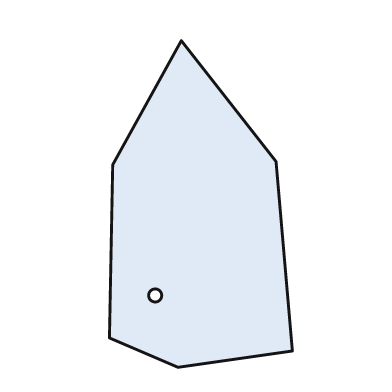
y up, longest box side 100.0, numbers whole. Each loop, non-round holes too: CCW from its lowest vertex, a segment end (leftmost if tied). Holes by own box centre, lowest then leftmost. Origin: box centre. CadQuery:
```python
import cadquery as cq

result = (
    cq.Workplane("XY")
    .moveTo(-7.0, -50.0)
    .lineTo(28.0, -45.0)
    .lineTo(23.0, 13.0)
    .lineTo(-6.0, 50.0)
    .lineTo(-27.0, 12.0)
    .lineTo(-28.0, -41.0)
    .close()
    .moveTo(-14.0, -28.0)
    .circle(2.0)
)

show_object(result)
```